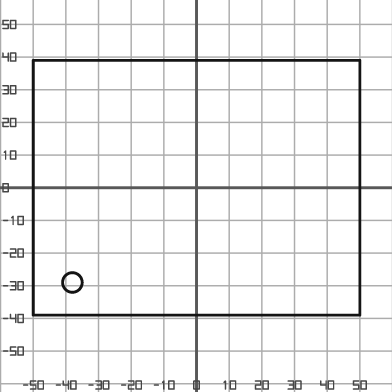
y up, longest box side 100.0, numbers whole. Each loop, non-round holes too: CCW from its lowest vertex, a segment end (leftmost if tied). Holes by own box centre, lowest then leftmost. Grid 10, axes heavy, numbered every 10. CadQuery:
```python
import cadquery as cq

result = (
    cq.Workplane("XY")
    .moveTo(-50.0, -39.0)
    .lineTo(50.0, -39.0)
    .lineTo(50.0, 39.0)
    .lineTo(-50.0, 39.0)
    .close()
    .moveTo(-38.0, -29.0)
    .circle(3.0)
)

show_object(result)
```